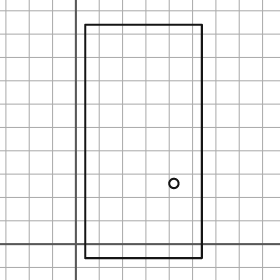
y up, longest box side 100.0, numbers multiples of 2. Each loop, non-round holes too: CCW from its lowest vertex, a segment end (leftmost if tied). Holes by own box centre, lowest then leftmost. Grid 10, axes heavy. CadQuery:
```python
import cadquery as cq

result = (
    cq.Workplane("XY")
    .moveTo(4.0, -6.0)
    .lineTo(54.0, -6.0)
    .lineTo(54.0, 94.0)
    .lineTo(4.0, 94.0)
    .close()
    .moveTo(42.0, 26.0)
    .circle(2.0)
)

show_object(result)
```